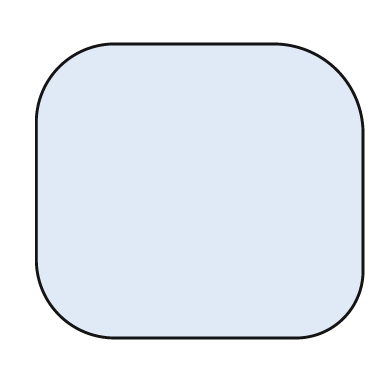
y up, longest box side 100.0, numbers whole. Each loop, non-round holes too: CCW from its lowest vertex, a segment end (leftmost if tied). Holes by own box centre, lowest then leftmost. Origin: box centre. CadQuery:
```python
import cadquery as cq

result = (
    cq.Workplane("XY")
    .moveTo(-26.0, -45.0)
    .lineTo(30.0, -45.0)
    .threePointArc((44.0, -39.0), (50.0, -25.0))
    .lineTo(50.0, 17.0)
    .threePointArc((42.0, 37.0), (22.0, 45.0))
    .lineTo(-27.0, 45.0)
    .threePointArc((-43.0, 38.0), (-50.0, 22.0))
    .lineTo(-50.0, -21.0)
    .threePointArc((-43.0, -38.0), (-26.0, -45.0))
    .close()
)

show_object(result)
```